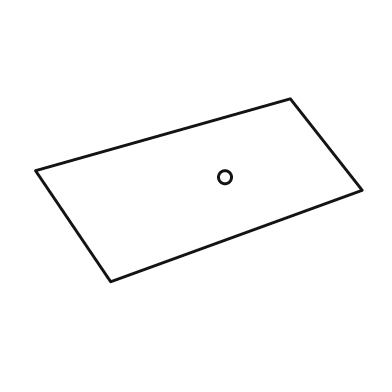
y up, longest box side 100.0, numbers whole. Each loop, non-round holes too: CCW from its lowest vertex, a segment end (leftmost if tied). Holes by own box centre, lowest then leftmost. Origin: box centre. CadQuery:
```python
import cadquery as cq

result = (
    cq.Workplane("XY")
    .moveTo(-27.0, -28.0)
    .lineTo(50.0, 0.0)
    .lineTo(28.0, 28.0)
    .lineTo(-50.0, 6.0)
    .close()
    .moveTo(8.0, 4.0)
    .circle(2.0)
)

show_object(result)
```